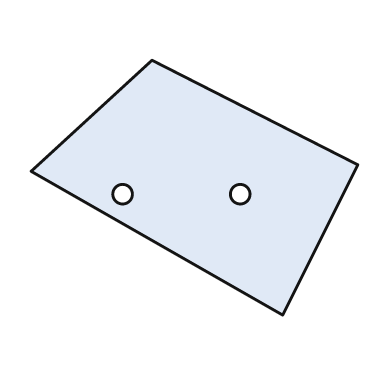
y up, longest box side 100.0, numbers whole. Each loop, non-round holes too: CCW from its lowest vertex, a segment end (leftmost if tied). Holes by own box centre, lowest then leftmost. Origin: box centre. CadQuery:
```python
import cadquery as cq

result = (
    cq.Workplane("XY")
    .moveTo(27.0, -39.0)
    .lineTo(50.0, 7.0)
    .lineTo(-13.0, 39.0)
    .lineTo(-50.0, 5.0)
    .close()
    .moveTo(-22.0, -2.0)
    .circle(3.0)
    .moveTo(14.0, -2.0)
    .circle(3.0)
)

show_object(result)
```